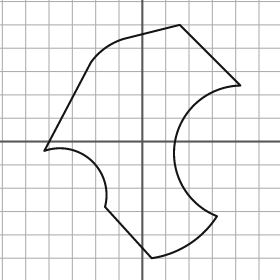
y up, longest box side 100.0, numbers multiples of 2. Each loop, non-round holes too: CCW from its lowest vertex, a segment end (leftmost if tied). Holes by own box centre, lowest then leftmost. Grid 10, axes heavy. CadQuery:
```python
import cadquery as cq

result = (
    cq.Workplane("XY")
    .moveTo(4.0, -50.0)
    .threePointArc((20.0, -44.0), (32.0, -32.0))
    .threePointArc((14.0, 0.0), (42.0, 24.0))
    .lineTo(16.0, 50.0)
    .lineTo(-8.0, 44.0)
    .threePointArc((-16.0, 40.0), (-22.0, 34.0))
    .lineTo(-42.0, -4.0)
    .threePointArc((-22.0, -8.0), (-16.0, -28.0))
    .close()
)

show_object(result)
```